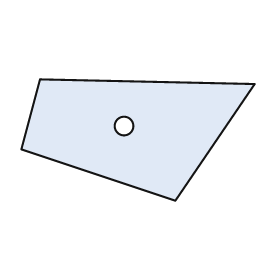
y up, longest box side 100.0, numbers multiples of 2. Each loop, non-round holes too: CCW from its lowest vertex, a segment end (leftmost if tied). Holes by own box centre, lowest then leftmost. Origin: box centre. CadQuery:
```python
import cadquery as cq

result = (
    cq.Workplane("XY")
    .moveTo(16.0, -26.0)
    .lineTo(50.0, 24.0)
    .lineTo(-42.0, 26.0)
    .lineTo(-50.0, -4.0)
    .close()
    .moveTo(-6.0, 6.0)
    .circle(4.0)
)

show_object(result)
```